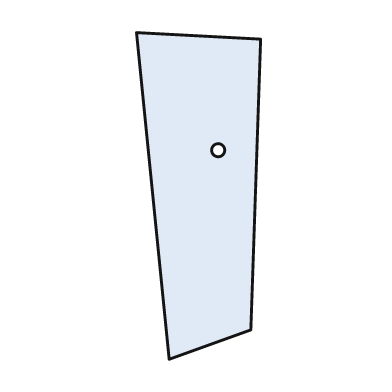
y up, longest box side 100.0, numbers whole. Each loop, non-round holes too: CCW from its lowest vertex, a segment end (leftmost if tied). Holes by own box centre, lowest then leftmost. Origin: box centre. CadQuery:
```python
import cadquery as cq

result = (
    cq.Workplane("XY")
    .moveTo(-9.0, -50.0)
    .lineTo(16.0, -41.0)
    .lineTo(19.0, 48.0)
    .lineTo(-19.0, 50.0)
    .close()
    .moveTo(6.0, 14.0)
    .circle(2.0)
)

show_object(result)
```